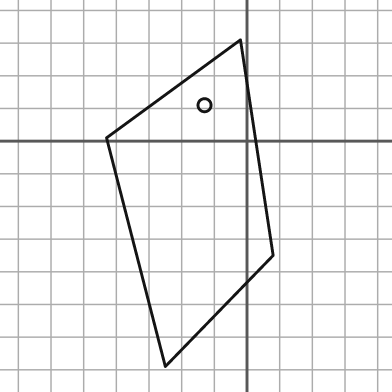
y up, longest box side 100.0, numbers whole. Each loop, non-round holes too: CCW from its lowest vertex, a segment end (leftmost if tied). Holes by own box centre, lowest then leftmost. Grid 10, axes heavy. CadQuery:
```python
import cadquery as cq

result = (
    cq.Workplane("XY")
    .moveTo(-25.0, -69.0)
    .lineTo(8.0, -35.0)
    .lineTo(-2.0, 31.0)
    .lineTo(-43.0, 1.0)
    .close()
    .moveTo(-13.0, 11.0)
    .circle(2.0)
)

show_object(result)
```